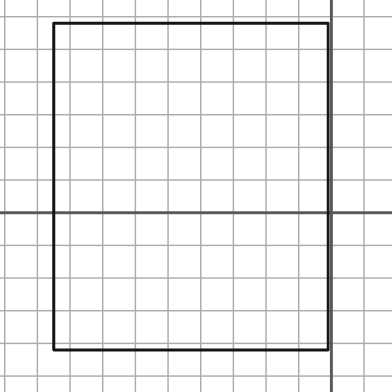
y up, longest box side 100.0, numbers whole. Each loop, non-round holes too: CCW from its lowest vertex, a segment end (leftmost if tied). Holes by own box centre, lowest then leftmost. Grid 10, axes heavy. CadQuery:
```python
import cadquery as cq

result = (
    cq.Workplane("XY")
    .moveTo(-85.0, -42.0)
    .lineTo(-1.0, -42.0)
    .lineTo(-1.0, 58.0)
    .lineTo(-85.0, 58.0)
    .close()
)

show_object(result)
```